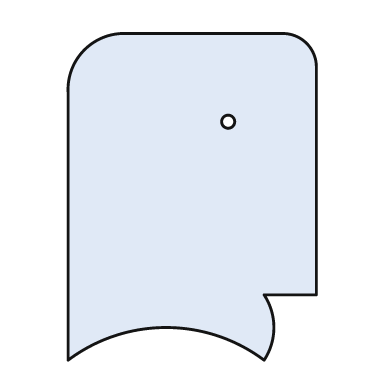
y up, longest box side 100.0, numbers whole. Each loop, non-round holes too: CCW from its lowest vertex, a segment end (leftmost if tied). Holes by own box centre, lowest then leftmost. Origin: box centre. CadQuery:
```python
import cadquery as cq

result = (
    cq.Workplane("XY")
    .moveTo(-38.0, -50.0)
    .threePointArc((-8.0, -40.0), (22.0, -50.0))
    .threePointArc((25.0, -40.0), (22.0, -30.0))
    .lineTo(38.0, -30.0)
    .lineTo(38.0, 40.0)
    .threePointArc((35.0, 47.0), (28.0, 50.0))
    .lineTo(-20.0, 50.0)
    .threePointArc((-33.0, 45.0), (-38.0, 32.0))
    .close()
    .moveTo(11.0, 23.0)
    .circle(2.0)
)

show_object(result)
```